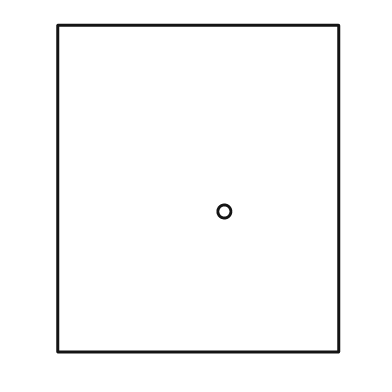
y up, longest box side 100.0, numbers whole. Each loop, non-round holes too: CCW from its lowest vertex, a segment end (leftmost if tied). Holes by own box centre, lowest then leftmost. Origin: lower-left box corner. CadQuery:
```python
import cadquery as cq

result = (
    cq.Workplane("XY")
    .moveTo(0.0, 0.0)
    .lineTo(86.0, 0.0)
    .lineTo(86.0, 100.0)
    .lineTo(0.0, 100.0)
    .close()
    .moveTo(51.0, 43.0)
    .circle(2.0)
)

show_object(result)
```